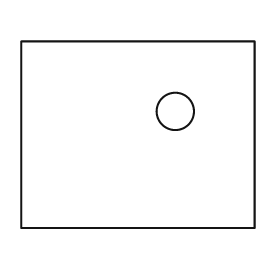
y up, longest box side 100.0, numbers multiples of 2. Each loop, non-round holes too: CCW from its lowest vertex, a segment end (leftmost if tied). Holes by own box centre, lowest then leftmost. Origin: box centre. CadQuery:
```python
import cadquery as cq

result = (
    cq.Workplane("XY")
    .moveTo(-50.0, -40.0)
    .lineTo(50.0, -40.0)
    .lineTo(50.0, 40.0)
    .lineTo(-50.0, 40.0)
    .close()
    .moveTo(16.0, 10.0)
    .circle(8.0)
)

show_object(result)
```